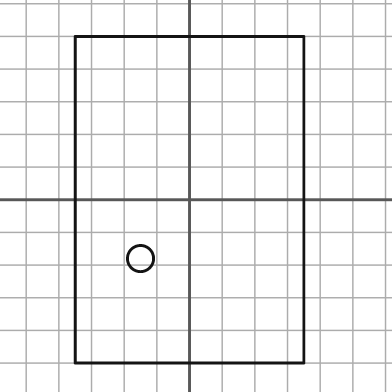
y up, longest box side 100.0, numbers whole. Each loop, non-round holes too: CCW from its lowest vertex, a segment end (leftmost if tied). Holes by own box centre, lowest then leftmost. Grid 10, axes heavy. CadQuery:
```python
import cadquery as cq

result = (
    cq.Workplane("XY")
    .moveTo(-35.0, -50.0)
    .lineTo(35.0, -50.0)
    .lineTo(35.0, 50.0)
    .lineTo(-35.0, 50.0)
    .close()
    .moveTo(-15.0, -18.0)
    .circle(4.0)
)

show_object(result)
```